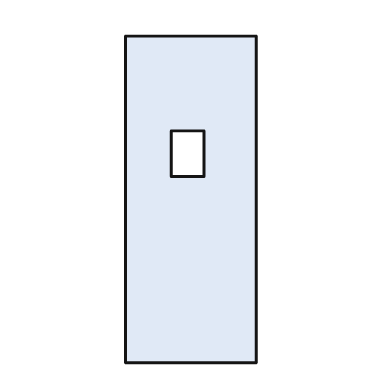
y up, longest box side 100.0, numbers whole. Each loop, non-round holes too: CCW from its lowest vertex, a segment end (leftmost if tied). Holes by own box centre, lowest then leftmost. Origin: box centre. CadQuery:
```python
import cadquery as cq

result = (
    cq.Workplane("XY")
    .moveTo(-20.0, -50.0)
    .lineTo(20.0, -50.0)
    .lineTo(20.0, 50.0)
    .lineTo(-20.0, 50.0)
    .close()
    .moveTo(-6.0, 7.0)
    .lineTo(4.0, 7.0)
    .lineTo(4.0, 21.0)
    .lineTo(-6.0, 21.0)
    .close()
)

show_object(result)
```